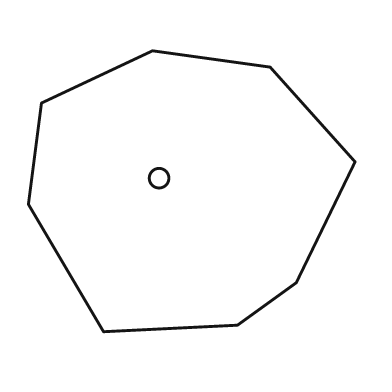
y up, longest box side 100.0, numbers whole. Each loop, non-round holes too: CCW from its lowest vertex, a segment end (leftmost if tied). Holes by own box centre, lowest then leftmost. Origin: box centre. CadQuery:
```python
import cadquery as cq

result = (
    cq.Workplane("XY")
    .moveTo(-27.0, -43.0)
    .lineTo(14.0, -41.0)
    .lineTo(32.0, -28.0)
    .lineTo(50.0, 9.0)
    .lineTo(24.0, 38.0)
    .lineTo(-12.0, 43.0)
    .lineTo(-46.0, 27.0)
    .lineTo(-50.0, -4.0)
    .close()
    .moveTo(-10.0, 4.0)
    .circle(3.0)
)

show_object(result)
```